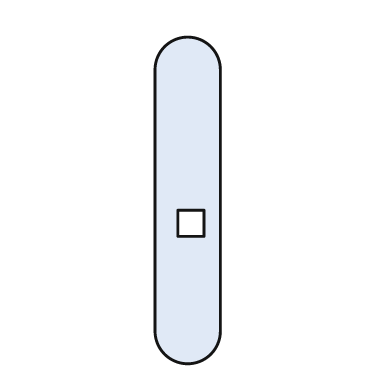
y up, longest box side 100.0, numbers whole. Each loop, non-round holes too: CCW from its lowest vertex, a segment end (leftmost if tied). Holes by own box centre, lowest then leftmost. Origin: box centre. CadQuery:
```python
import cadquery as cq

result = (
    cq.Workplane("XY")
    .moveTo(-10.0, -40.0)
    .threePointArc((0.0, -50.0), (10.0, -40.0))
    .lineTo(10.0, 40.0)
    .threePointArc((0.0, 50.0), (-10.0, 40.0))
    .close()
    .moveTo(-3.0, -11.0)
    .lineTo(5.0, -11.0)
    .lineTo(5.0, -3.0)
    .lineTo(-3.0, -3.0)
    .close()
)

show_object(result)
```